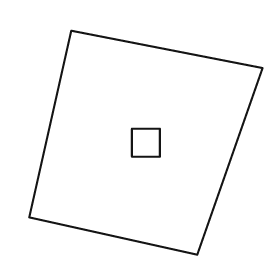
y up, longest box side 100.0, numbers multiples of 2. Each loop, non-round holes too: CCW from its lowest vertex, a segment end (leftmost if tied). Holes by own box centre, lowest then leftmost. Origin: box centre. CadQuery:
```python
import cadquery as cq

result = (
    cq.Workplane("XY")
    .moveTo(22.0, -48.0)
    .lineTo(50.0, 32.0)
    .lineTo(-32.0, 48.0)
    .lineTo(-50.0, -32.0)
    .close()
    .moveTo(-6.0, -6.0)
    .lineTo(6.0, -6.0)
    .lineTo(6.0, 6.0)
    .lineTo(-6.0, 6.0)
    .close()
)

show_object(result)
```